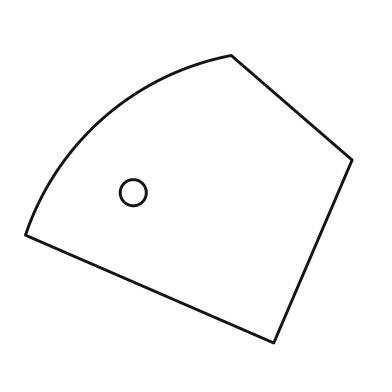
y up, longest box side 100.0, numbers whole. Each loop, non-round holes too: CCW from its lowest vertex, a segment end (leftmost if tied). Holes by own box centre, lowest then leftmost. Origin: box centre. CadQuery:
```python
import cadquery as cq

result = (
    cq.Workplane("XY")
    .moveTo(26.0, -44.0)
    .lineTo(50.0, 12.0)
    .lineTo(13.0, 44.0)
    .threePointArc((-26.0, 25.0), (-50.0, -11.0))
    .close()
    .moveTo(-17.0, 2.0)
    .circle(4.0)
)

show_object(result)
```